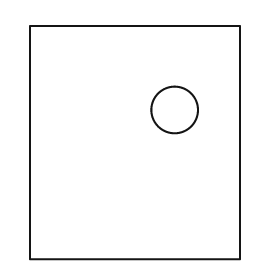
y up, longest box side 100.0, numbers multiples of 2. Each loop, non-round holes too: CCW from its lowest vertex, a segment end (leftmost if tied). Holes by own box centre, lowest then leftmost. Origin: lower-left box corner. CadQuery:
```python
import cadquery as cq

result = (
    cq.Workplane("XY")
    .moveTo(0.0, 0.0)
    .lineTo(90.0, 0.0)
    .lineTo(90.0, 100.0)
    .lineTo(0.0, 100.0)
    .close()
    .moveTo(62.0, 64.0)
    .circle(10.0)
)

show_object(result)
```